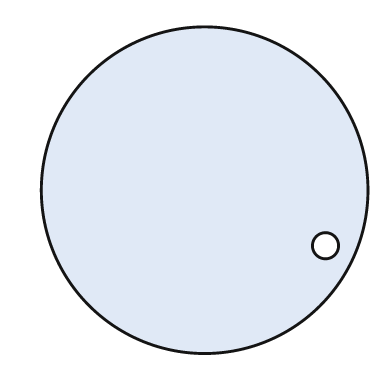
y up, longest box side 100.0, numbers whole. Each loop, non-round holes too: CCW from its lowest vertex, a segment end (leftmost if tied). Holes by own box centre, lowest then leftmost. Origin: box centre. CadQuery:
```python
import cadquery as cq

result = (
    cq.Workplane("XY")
    .moveTo(0.0, 0.0)
    .circle(50.0)
    .moveTo(37.0, -17.0)
    .circle(4.0)
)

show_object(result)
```